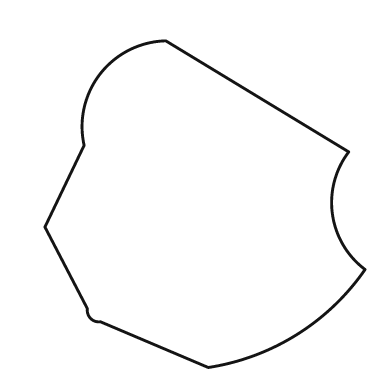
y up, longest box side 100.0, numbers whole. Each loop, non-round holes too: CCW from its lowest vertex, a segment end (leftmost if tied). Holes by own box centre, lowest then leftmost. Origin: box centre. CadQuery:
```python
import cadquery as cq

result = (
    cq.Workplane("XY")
    .moveTo(1.0, -50.0)
    .threePointArc((28.0, -40.0), (49.0, -20.0))
    .threePointArc((39.0, -3.0), (44.0, 16.0))
    .lineTo(-12.0, 50.0)
    .threePointArc((-32.0, 40.0), (-37.0, 18.0))
    .lineTo(-49.0, -7.0)
    .lineTo(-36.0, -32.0)
    .threePointArc((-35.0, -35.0), (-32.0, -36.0))
    .close()
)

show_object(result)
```